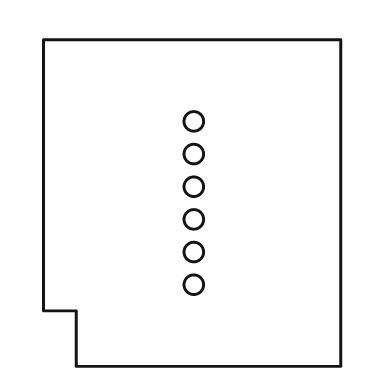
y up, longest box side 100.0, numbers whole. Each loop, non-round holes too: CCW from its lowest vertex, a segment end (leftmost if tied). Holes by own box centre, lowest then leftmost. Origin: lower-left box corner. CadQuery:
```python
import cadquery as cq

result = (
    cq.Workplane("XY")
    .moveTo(10.0, 0.0)
    .lineTo(91.0, 0.0)
    .lineTo(91.0, 100.0)
    .lineTo(0.0, 100.0)
    .lineTo(0.0, 17.0)
    .lineTo(10.0, 17.0)
    .close()
    .moveTo(46.0, 25.0)
    .circle(3.0)
    .moveTo(46.0, 35.0)
    .circle(3.0)
    .moveTo(46.0, 45.0)
    .circle(3.0)
    .moveTo(46.0, 55.0)
    .circle(3.0)
    .moveTo(46.0, 65.0)
    .circle(3.0)
    .moveTo(46.0, 75.0)
    .circle(3.0)
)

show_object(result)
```